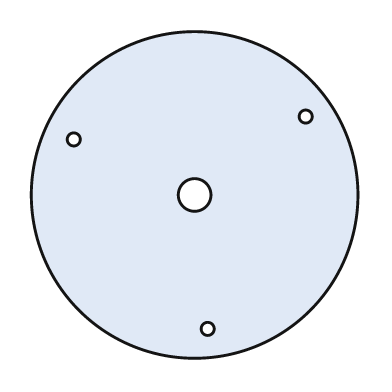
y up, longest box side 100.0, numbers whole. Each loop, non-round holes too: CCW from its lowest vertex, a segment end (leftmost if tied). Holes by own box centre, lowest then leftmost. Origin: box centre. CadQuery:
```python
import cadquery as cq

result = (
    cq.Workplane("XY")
    .moveTo(0.0, 0.0)
    .circle(50.0)
    .moveTo(4.0, -41.0)
    .circle(2.0)
    .moveTo(0.0, 0.0)
    .circle(5.0)
    .moveTo(-37.0, 17.0)
    .circle(2.0)
    .moveTo(34.0, 24.0)
    .circle(2.0)
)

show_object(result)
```